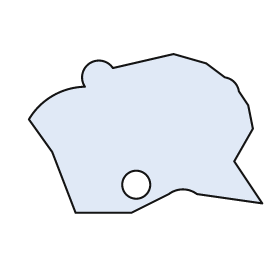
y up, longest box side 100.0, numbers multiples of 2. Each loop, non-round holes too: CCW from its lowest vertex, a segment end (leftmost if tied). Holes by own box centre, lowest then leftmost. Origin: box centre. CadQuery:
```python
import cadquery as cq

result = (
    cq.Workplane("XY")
    .moveTo(-30.0, -34.0)
    .lineTo(-6.0, -34.0)
    .lineTo(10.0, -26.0)
    .threePointArc((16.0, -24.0), (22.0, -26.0))
    .lineTo(50.0, -30.0)
    .lineTo(38.0, -12.0)
    .lineTo(46.0, 2.0)
    .lineTo(44.0, 12.0)
    .lineTo(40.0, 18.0)
    .threePointArc((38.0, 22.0), (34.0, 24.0))
    .lineTo(26.0, 30.0)
    .lineTo(12.0, 34.0)
    .lineTo(-14.0, 28.0)
    .threePointArc((-24.0, 30.0), (-26.0, 20.0))
    .threePointArc((-40.0, 16.0), (-50.0, 6.0))
    .lineTo(-40.0, -8.0)
    .close()
    .moveTo(-4.0, -22.0)
    .circle(6.0)
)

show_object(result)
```